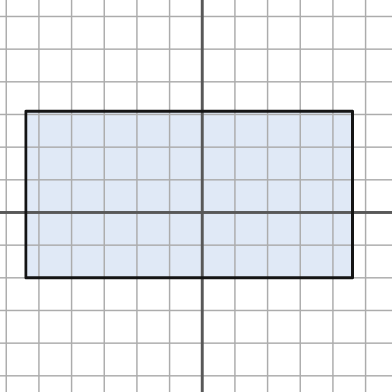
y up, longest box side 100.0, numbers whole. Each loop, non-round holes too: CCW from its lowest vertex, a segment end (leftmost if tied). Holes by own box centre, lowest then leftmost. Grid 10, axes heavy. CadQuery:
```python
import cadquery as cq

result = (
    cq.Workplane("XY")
    .moveTo(-54.0, -20.0)
    .lineTo(46.0, -20.0)
    .lineTo(46.0, 31.0)
    .lineTo(-54.0, 31.0)
    .close()
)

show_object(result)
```